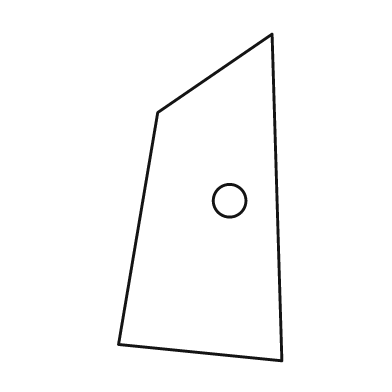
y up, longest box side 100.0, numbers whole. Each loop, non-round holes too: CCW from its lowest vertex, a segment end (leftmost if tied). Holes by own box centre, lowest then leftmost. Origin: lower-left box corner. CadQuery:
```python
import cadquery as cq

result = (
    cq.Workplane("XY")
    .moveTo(50.0, 0.0)
    .lineTo(47.0, 100.0)
    .lineTo(12.0, 76.0)
    .lineTo(0.0, 5.0)
    .close()
    .moveTo(34.0, 49.0)
    .circle(5.0)
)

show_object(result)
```